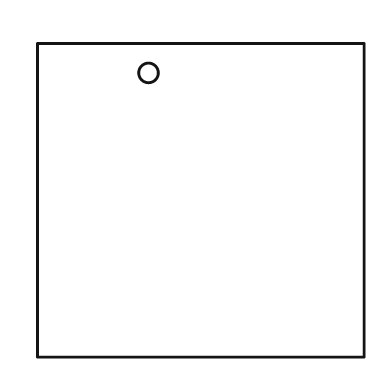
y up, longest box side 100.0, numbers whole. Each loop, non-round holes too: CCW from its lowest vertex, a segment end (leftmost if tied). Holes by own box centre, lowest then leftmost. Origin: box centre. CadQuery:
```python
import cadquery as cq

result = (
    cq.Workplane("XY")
    .moveTo(-50.0, -48.0)
    .lineTo(50.0, -48.0)
    .lineTo(50.0, 48.0)
    .lineTo(-50.0, 48.0)
    .close()
    .moveTo(-16.0, 39.0)
    .circle(3.0)
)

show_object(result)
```